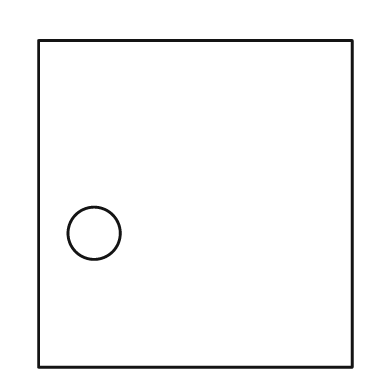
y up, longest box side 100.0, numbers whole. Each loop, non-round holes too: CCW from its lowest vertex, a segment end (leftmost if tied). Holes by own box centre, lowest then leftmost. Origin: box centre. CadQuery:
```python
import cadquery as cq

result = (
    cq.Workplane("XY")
    .moveTo(-48.0, -50.0)
    .lineTo(48.0, -50.0)
    .lineTo(48.0, 50.0)
    .lineTo(-48.0, 50.0)
    .close()
    .moveTo(-31.0, -9.0)
    .circle(8.0)
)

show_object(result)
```